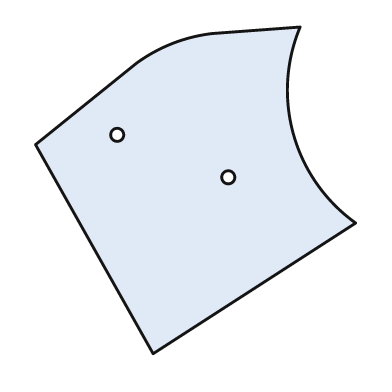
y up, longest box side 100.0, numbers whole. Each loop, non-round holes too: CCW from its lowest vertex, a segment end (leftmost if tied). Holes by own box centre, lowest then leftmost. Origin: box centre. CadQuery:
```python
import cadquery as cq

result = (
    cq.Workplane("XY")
    .moveTo(-13.0, -50.0)
    .lineTo(49.0, -10.0)
    .threePointArc((30.0, 17.0), (32.0, 50.0))
    .lineTo(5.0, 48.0)
    .threePointArc((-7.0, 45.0), (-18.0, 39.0))
    .lineTo(-49.0, 14.0)
    .close()
    .moveTo(10.0, 4.0)
    .circle(2.0)
    .moveTo(-24.0, 17.0)
    .circle(2.0)
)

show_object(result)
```